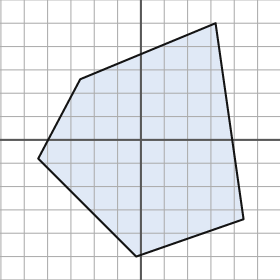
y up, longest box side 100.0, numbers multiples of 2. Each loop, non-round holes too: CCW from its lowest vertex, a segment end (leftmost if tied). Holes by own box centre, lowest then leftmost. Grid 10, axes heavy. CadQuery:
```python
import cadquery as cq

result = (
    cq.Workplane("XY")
    .moveTo(-2.0, -50.0)
    .lineTo(44.0, -34.0)
    .lineTo(32.0, 50.0)
    .lineTo(-26.0, 26.0)
    .lineTo(-44.0, -8.0)
    .close()
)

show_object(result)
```